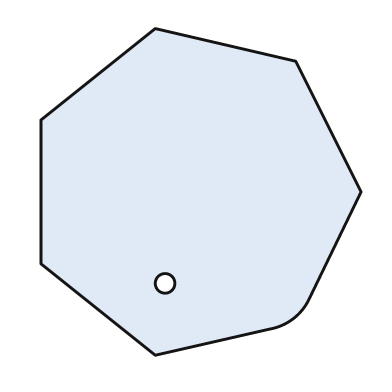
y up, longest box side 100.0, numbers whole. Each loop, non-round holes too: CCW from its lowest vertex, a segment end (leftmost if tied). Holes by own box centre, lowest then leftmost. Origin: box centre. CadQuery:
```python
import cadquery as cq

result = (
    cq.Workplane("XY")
    .moveTo(-14.0, -50.0)
    .lineTo(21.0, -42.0)
    .threePointArc((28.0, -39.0), (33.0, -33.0))
    .lineTo(49.0, 0.0)
    .lineTo(29.0, 40.0)
    .lineTo(-14.0, 50.0)
    .lineTo(-49.0, 22.0)
    .lineTo(-49.0, -22.0)
    .close()
    .moveTo(-11.0, -28.0)
    .circle(3.0)
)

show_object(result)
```